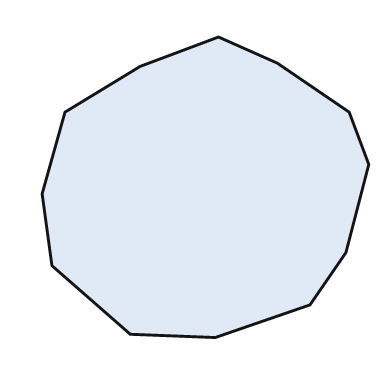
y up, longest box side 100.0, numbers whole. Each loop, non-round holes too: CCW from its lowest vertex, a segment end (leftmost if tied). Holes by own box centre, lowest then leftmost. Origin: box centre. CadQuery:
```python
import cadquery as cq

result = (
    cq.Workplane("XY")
    .moveTo(3.0, -46.0)
    .lineTo(32.0, -36.0)
    .lineTo(43.0, -20.0)
    .lineTo(50.0, 7.0)
    .lineTo(44.0, 23.0)
    .lineTo(22.0, 38.0)
    .lineTo(4.0, 46.0)
    .lineTo(-20.0, 37.0)
    .lineTo(-43.0, 23.0)
    .lineTo(-50.0, -2.0)
    .lineTo(-47.0, -24.0)
    .lineTo(-23.0, -45.0)
    .close()
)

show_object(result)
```